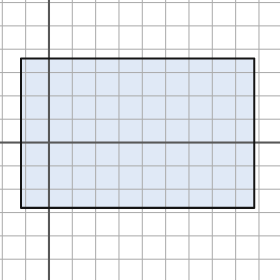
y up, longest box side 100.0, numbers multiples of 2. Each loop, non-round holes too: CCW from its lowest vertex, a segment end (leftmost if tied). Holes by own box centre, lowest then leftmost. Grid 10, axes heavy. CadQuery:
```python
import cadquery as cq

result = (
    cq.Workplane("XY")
    .moveTo(-12.0, -28.0)
    .lineTo(88.0, -28.0)
    .lineTo(88.0, 36.0)
    .lineTo(-12.0, 36.0)
    .close()
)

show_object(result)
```